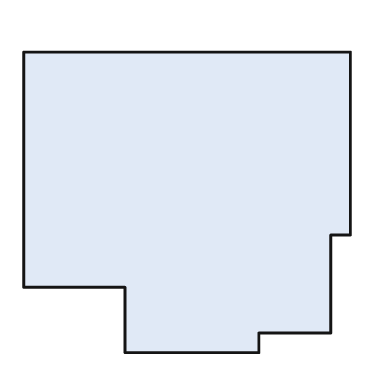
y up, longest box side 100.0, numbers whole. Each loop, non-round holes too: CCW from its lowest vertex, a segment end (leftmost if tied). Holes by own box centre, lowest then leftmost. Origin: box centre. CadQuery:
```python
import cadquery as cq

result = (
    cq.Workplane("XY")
    .moveTo(-19.0, -46.0)
    .lineTo(22.0, -46.0)
    .lineTo(22.0, -40.0)
    .lineTo(44.0, -40.0)
    .lineTo(44.0, -10.0)
    .lineTo(50.0, -10.0)
    .lineTo(50.0, 46.0)
    .lineTo(-50.0, 46.0)
    .lineTo(-50.0, -26.0)
    .lineTo(-19.0, -26.0)
    .close()
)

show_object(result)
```